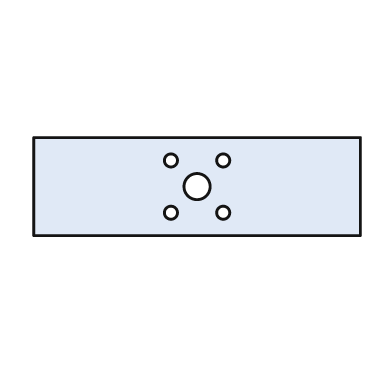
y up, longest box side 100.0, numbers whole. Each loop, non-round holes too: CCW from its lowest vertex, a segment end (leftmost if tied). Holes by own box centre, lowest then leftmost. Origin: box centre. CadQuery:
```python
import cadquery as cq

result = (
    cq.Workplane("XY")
    .moveTo(-50.0, -15.0)
    .lineTo(50.0, -15.0)
    .lineTo(50.0, 15.0)
    .lineTo(-50.0, 15.0)
    .close()
    .moveTo(-8.0, -8.0)
    .circle(2.0)
    .moveTo(8.0, -8.0)
    .circle(2.0)
    .moveTo(0.0, 0.0)
    .circle(4.0)
    .moveTo(-8.0, 8.0)
    .circle(2.0)
    .moveTo(8.0, 8.0)
    .circle(2.0)
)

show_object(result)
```